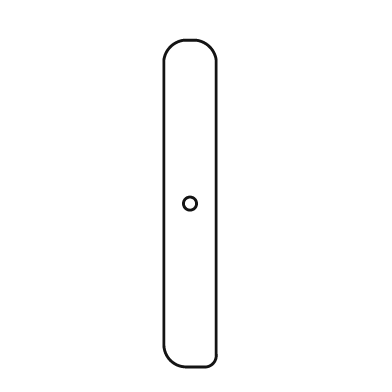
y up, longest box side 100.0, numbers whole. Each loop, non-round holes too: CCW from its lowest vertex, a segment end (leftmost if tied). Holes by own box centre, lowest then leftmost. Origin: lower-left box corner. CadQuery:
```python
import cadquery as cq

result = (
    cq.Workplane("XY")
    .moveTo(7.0, 0.0)
    .lineTo(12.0, 0.0)
    .threePointArc((15.0, 1.0), (16.0, 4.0))
    .lineTo(16.0, 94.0)
    .threePointArc((14.0, 98.0), (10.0, 100.0))
    .lineTo(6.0, 100.0)
    .threePointArc((2.0, 98.0), (0.0, 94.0))
    .lineTo(0.0, 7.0)
    .threePointArc((2.0, 2.0), (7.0, 0.0))
    .close()
    .moveTo(8.0, 50.0)
    .circle(2.0)
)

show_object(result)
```